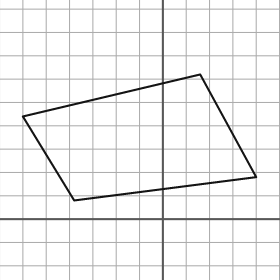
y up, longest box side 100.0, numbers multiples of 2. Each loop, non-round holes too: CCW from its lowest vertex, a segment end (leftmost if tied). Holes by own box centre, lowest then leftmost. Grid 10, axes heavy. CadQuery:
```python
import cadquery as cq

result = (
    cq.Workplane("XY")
    .moveTo(-38.0, 8.0)
    .lineTo(40.0, 18.0)
    .lineTo(16.0, 62.0)
    .lineTo(-60.0, 44.0)
    .close()
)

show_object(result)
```